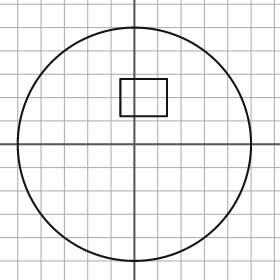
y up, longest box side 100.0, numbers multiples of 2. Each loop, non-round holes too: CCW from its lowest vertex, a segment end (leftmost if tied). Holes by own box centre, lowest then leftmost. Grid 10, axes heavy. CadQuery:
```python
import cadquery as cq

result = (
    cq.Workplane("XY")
    .moveTo(0.0, 0.0)
    .circle(50.0)
    .moveTo(-6.0, 12.0)
    .lineTo(14.0, 12.0)
    .lineTo(14.0, 28.0)
    .lineTo(-6.0, 28.0)
    .close()
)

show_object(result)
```